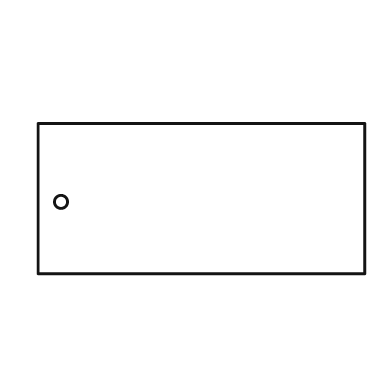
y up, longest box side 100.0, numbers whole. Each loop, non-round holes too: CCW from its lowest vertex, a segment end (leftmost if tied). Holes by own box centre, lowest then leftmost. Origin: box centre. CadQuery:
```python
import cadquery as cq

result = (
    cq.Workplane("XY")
    .moveTo(-50.0, -23.0)
    .lineTo(50.0, -23.0)
    .lineTo(50.0, 23.0)
    .lineTo(-50.0, 23.0)
    .close()
    .moveTo(-43.0, -1.0)
    .circle(2.0)
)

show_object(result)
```